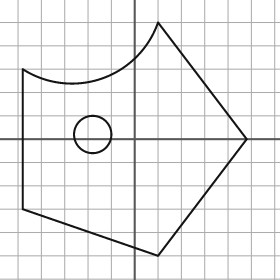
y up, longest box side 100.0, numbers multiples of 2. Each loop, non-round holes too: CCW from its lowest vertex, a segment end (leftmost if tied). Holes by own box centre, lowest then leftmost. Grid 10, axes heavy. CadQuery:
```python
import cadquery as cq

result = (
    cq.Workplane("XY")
    .moveTo(10.0, -50.0)
    .lineTo(48.0, 0.0)
    .lineTo(10.0, 50.0)
    .threePointArc((-14.0, 26.0), (-48.0, 30.0))
    .lineTo(-48.0, -30.0)
    .close()
    .moveTo(-18.0, 2.0)
    .circle(8.0)
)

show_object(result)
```